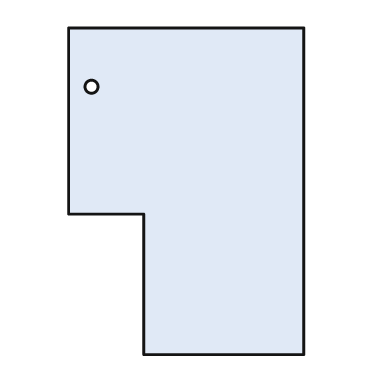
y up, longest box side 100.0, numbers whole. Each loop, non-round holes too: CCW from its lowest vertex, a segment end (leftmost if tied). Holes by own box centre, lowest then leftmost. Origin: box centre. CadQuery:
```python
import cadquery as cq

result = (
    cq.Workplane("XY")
    .moveTo(-13.0, -50.0)
    .lineTo(36.0, -50.0)
    .lineTo(36.0, 50.0)
    .lineTo(-36.0, 50.0)
    .lineTo(-36.0, -7.0)
    .lineTo(-13.0, -7.0)
    .close()
    .moveTo(-29.0, 32.0)
    .circle(2.0)
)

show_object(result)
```